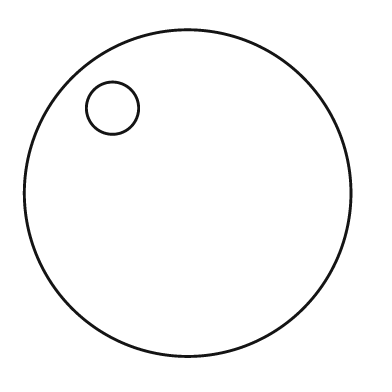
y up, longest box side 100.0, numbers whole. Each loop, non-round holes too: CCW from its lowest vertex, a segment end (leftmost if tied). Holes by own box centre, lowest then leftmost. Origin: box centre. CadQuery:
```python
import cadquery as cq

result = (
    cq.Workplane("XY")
    .moveTo(0.0, 0.0)
    .circle(50.0)
    .moveTo(-23.0, 26.0)
    .circle(8.0)
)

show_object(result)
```